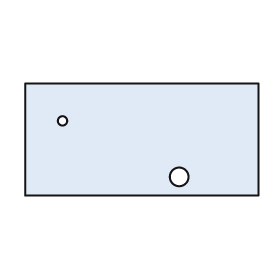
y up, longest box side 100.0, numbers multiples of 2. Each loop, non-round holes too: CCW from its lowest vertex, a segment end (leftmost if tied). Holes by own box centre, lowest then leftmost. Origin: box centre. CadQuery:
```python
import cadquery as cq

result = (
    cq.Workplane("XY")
    .moveTo(-50.0, -24.0)
    .lineTo(50.0, -24.0)
    .lineTo(50.0, 24.0)
    .lineTo(-50.0, 24.0)
    .close()
    .moveTo(16.0, -16.0)
    .circle(4.0)
    .moveTo(-34.0, 8.0)
    .circle(2.0)
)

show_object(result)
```